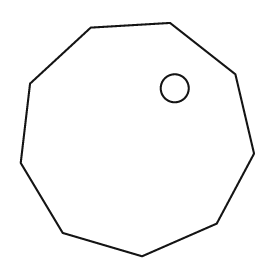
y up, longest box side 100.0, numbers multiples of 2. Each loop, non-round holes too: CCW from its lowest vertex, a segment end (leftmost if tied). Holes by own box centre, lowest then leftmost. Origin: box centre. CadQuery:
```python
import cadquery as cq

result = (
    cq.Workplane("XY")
    .moveTo(2.0, -50.0)
    .lineTo(34.0, -36.0)
    .lineTo(50.0, -6.0)
    .lineTo(42.0, 28.0)
    .lineTo(14.0, 50.0)
    .lineTo(-20.0, 48.0)
    .lineTo(-46.0, 24.0)
    .lineTo(-50.0, -10.0)
    .lineTo(-32.0, -40.0)
    .close()
    .moveTo(16.0, 22.0)
    .circle(6.0)
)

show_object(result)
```